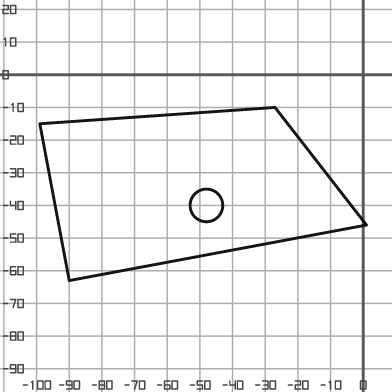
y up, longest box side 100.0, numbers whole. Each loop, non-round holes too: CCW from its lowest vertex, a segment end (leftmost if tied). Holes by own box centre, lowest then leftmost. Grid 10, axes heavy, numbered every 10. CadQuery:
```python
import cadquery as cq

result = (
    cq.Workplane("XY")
    .moveTo(-90.0, -63.0)
    .lineTo(1.0, -46.0)
    .lineTo(-27.0, -10.0)
    .lineTo(-99.0, -15.0)
    .close()
    .moveTo(-48.0, -40.0)
    .circle(5.0)
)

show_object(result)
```